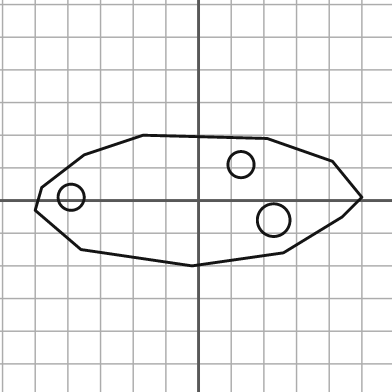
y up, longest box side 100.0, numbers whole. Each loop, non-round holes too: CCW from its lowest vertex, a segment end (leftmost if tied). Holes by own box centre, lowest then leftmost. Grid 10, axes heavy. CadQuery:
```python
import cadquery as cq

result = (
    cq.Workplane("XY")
    .moveTo(-2.0, -20.0)
    .lineTo(26.0, -16.0)
    .lineTo(44.0, -5.0)
    .lineTo(50.0, 1.0)
    .lineTo(41.0, 12.0)
    .lineTo(21.0, 19.0)
    .lineTo(-17.0, 20.0)
    .lineTo(-35.0, 14.0)
    .lineTo(-48.0, 4.0)
    .lineTo(-50.0, -3.0)
    .lineTo(-36.0, -15.0)
    .close()
    .moveTo(23.0, -6.0)
    .circle(5.0)
    .moveTo(-39.0, 1.0)
    .circle(4.0)
    .moveTo(13.0, 11.0)
    .circle(4.0)
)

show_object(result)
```